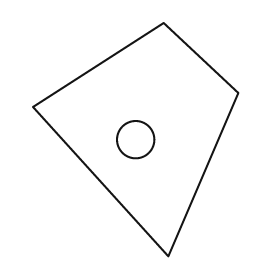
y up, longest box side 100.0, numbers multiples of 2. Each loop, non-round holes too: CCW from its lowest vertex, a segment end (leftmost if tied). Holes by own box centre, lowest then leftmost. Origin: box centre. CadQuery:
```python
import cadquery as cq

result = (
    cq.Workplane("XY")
    .moveTo(14.0, -50.0)
    .lineTo(44.0, 20.0)
    .lineTo(12.0, 50.0)
    .lineTo(-44.0, 14.0)
    .close()
    .moveTo(0.0, 0.0)
    .circle(8.0)
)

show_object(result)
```